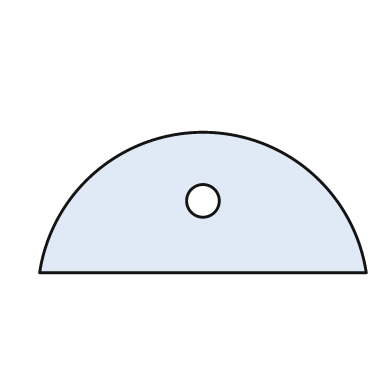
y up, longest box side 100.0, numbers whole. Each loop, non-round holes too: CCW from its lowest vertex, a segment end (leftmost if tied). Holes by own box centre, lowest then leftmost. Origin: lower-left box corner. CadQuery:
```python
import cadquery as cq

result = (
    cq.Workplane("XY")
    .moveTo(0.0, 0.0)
    .lineTo(100.0, 0.0)
    .threePointArc((50.0, 43.0), (0.0, 0.0))
    .close()
    .moveTo(50.0, 22.0)
    .circle(5.0)
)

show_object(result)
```